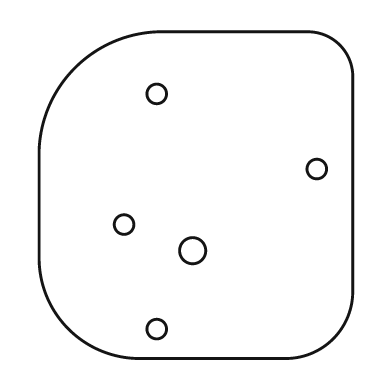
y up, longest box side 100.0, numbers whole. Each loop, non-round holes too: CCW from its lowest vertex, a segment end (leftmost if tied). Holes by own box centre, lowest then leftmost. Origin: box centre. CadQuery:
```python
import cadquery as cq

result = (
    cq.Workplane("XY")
    .moveTo(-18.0, -50.0)
    .lineTo(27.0, -50.0)
    .threePointArc((42.0, -44.0), (48.0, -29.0))
    .lineTo(48.0, 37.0)
    .threePointArc((44.0, 46.0), (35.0, 50.0))
    .lineTo(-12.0, 50.0)
    .threePointArc((-37.0, 39.0), (-48.0, 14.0))
    .lineTo(-48.0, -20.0)
    .threePointArc((-39.0, -41.0), (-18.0, -50.0))
    .close()
    .moveTo(-12.0, -41.0)
    .circle(3.0)
    .moveTo(-1.0, -17.0)
    .circle(4.0)
    .moveTo(-22.0, -9.0)
    .circle(3.0)
    .moveTo(37.0, 8.0)
    .circle(3.0)
    .moveTo(-12.0, 31.0)
    .circle(3.0)
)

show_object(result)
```